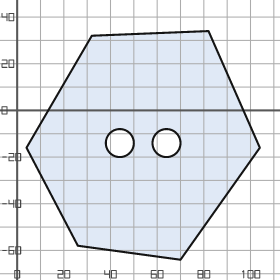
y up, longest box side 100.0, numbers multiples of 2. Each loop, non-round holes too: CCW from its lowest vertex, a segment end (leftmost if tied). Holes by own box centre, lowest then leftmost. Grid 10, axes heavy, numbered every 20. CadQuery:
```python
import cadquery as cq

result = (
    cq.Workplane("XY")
    .moveTo(70.0, -64.0)
    .lineTo(104.0, -16.0)
    .lineTo(82.0, 34.0)
    .lineTo(32.0, 32.0)
    .lineTo(4.0, -16.0)
    .lineTo(26.0, -58.0)
    .close()
    .moveTo(44.0, -14.0)
    .circle(6.0)
    .moveTo(64.0, -14.0)
    .circle(6.0)
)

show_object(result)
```